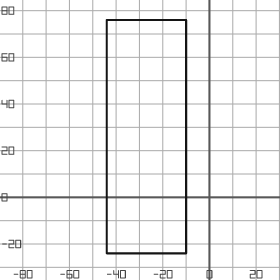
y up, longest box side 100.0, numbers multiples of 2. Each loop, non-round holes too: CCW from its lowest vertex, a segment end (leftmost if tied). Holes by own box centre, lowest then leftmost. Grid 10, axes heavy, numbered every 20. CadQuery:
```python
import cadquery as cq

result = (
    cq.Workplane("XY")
    .moveTo(-44.0, -24.0)
    .lineTo(-10.0, -24.0)
    .lineTo(-10.0, 76.0)
    .lineTo(-44.0, 76.0)
    .close()
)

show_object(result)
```